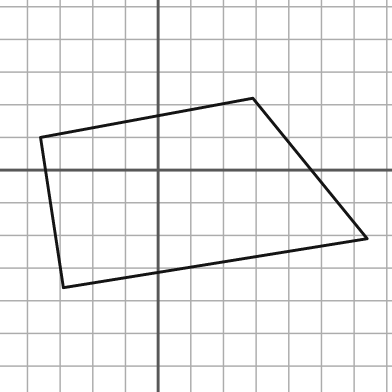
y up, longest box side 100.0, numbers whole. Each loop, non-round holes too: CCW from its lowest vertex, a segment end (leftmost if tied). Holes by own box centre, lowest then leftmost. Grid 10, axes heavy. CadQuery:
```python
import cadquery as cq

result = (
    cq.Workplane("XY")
    .moveTo(-29.0, -36.0)
    .lineTo(64.0, -21.0)
    .lineTo(29.0, 22.0)
    .lineTo(-36.0, 10.0)
    .close()
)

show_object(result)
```